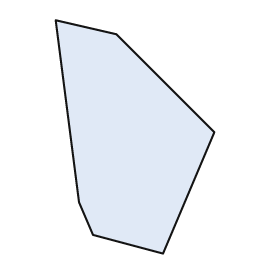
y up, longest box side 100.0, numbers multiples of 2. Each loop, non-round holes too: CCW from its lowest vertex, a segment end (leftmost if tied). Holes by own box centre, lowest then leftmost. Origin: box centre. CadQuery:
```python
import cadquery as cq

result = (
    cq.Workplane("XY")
    .moveTo(12.0, -50.0)
    .lineTo(34.0, 2.0)
    .lineTo(-8.0, 44.0)
    .lineTo(-34.0, 50.0)
    .lineTo(-24.0, -28.0)
    .lineTo(-18.0, -42.0)
    .close()
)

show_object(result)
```